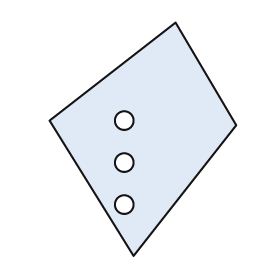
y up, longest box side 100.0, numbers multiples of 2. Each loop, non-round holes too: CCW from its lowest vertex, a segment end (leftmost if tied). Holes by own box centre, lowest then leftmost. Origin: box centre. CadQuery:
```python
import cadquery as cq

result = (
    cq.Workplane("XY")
    .moveTo(-4.0, -50.0)
    .lineTo(40.0, 6.0)
    .lineTo(14.0, 50.0)
    .lineTo(-40.0, 8.0)
    .close()
    .moveTo(-8.0, -28.0)
    .circle(4.0)
    .moveTo(-8.0, -10.0)
    .circle(4.0)
    .moveTo(-8.0, 8.0)
    .circle(4.0)
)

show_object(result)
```